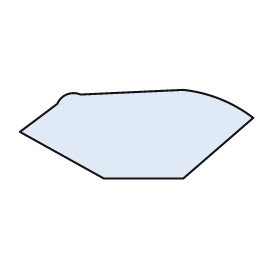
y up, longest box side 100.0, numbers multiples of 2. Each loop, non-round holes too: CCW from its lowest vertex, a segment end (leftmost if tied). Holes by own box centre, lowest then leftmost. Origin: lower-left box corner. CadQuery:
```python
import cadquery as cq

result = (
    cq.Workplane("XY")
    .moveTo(36.0, 0.0)
    .lineTo(70.0, 0.0)
    .lineTo(100.0, 26.0)
    .threePointArc((86.0, 34.0), (70.0, 38.0))
    .lineTo(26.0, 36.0)
    .threePointArc((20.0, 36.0), (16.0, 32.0))
    .lineTo(0.0, 20.0)
    .close()
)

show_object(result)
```